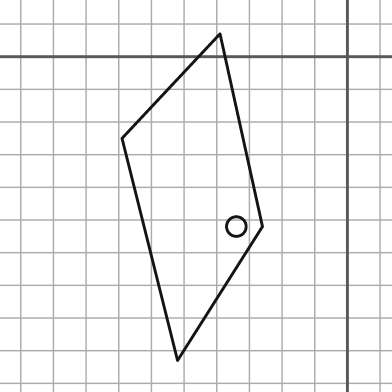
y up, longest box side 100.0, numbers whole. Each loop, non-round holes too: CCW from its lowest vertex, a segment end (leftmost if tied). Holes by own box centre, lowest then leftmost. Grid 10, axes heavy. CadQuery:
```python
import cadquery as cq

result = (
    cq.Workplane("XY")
    .moveTo(-52.0, -93.0)
    .lineTo(-26.0, -52.0)
    .lineTo(-39.0, 7.0)
    .lineTo(-69.0, -25.0)
    .close()
    .moveTo(-34.0, -52.0)
    .circle(3.0)
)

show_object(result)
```